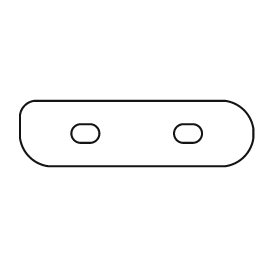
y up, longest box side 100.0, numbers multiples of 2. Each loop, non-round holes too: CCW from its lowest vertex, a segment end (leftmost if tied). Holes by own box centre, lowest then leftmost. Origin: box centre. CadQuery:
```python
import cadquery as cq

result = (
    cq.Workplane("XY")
    .moveTo(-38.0, -14.0)
    .lineTo(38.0, -14.0)
    .threePointArc((46.0, -10.0), (50.0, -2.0))
    .lineTo(50.0, 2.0)
    .threePointArc((46.0, 10.0), (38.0, 14.0))
    .lineTo(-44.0, 14.0)
    .threePointArc((-48.0, 12.0), (-50.0, 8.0))
    .lineTo(-50.0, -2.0)
    .threePointArc((-46.0, -10.0), (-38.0, -14.0))
    .close()
    .moveTo(-24.0, -4.0)
    .lineTo(-20.0, -4.0)
    .threePointArc((-16.0, 0.0), (-20.0, 4.0))
    .lineTo(-24.0, 4.0)
    .threePointArc((-28.0, 0.0), (-24.0, -4.0))
    .close()
    .moveTo(20.0, -4.0)
    .lineTo(24.0, -4.0)
    .threePointArc((28.0, 0.0), (24.0, 4.0))
    .lineTo(20.0, 4.0)
    .threePointArc((16.0, 0.0), (20.0, -4.0))
    .close()
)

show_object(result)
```